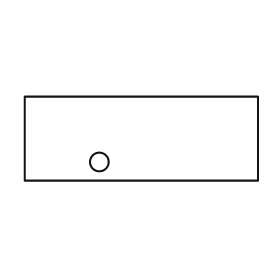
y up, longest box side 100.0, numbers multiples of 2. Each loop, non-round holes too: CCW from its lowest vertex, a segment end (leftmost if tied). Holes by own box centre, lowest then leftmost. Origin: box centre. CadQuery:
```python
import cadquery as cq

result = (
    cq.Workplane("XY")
    .moveTo(-50.0, -18.0)
    .lineTo(50.0, -18.0)
    .lineTo(50.0, 18.0)
    .lineTo(-50.0, 18.0)
    .close()
    .moveTo(-18.0, -10.0)
    .circle(4.0)
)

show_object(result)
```